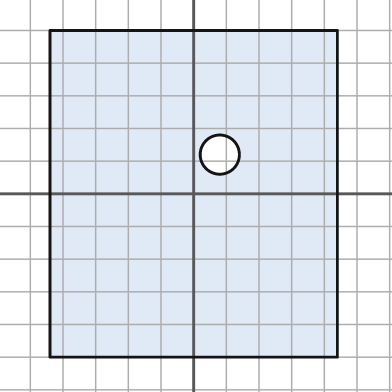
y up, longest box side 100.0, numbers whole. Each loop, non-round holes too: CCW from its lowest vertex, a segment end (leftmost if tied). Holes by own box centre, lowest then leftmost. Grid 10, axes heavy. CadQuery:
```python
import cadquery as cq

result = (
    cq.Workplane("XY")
    .moveTo(-44.0, -50.0)
    .lineTo(44.0, -50.0)
    .lineTo(44.0, 50.0)
    .lineTo(-44.0, 50.0)
    .close()
    .moveTo(8.0, 12.0)
    .circle(6.0)
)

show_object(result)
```